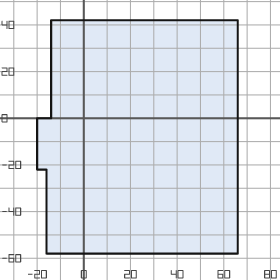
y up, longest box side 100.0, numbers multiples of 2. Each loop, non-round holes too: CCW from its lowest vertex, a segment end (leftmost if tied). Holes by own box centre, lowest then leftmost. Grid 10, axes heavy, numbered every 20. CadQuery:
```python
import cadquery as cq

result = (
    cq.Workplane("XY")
    .moveTo(-16.0, -58.0)
    .lineTo(66.0, -58.0)
    .lineTo(66.0, 42.0)
    .lineTo(-14.0, 42.0)
    .lineTo(-14.0, 0.0)
    .lineTo(-20.0, 0.0)
    .lineTo(-20.0, -22.0)
    .lineTo(-16.0, -22.0)
    .close()
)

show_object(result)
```